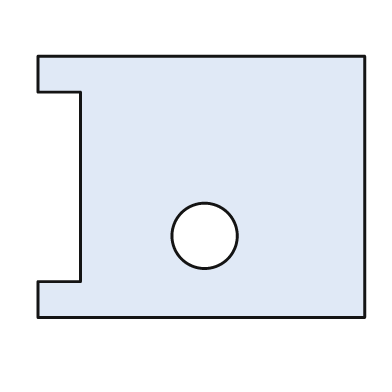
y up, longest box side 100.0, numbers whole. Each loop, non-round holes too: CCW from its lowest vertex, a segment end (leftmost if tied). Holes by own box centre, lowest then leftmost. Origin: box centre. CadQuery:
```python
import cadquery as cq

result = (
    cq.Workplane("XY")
    .moveTo(-50.0, -40.0)
    .lineTo(50.0, -40.0)
    .lineTo(50.0, 40.0)
    .lineTo(-50.0, 40.0)
    .lineTo(-50.0, 29.0)
    .lineTo(-37.0, 29.0)
    .lineTo(-37.0, -29.0)
    .lineTo(-50.0, -29.0)
    .close()
    .moveTo(1.0, -15.0)
    .circle(10.0)
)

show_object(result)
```